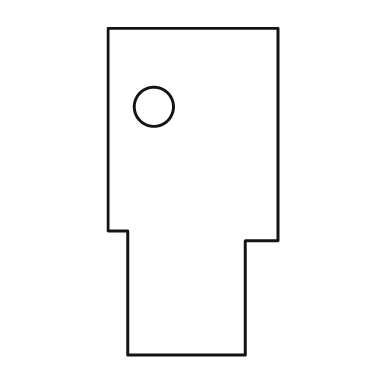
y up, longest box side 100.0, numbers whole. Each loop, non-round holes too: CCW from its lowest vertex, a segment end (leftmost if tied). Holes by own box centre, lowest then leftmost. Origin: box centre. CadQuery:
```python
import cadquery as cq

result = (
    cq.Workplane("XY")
    .moveTo(-20.0, -50.0)
    .lineTo(16.0, -50.0)
    .lineTo(16.0, -15.0)
    .lineTo(26.0, -15.0)
    .lineTo(26.0, 50.0)
    .lineTo(-26.0, 50.0)
    .lineTo(-26.0, -12.0)
    .lineTo(-20.0, -12.0)
    .close()
    .moveTo(-12.0, 26.0)
    .circle(6.0)
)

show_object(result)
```